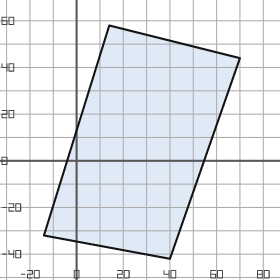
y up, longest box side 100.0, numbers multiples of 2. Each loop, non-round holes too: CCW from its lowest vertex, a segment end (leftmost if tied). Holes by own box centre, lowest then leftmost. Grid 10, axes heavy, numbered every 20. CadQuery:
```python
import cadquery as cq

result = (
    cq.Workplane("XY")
    .moveTo(40.0, -42.0)
    .lineTo(70.0, 44.0)
    .lineTo(14.0, 58.0)
    .lineTo(-14.0, -32.0)
    .close()
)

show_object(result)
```